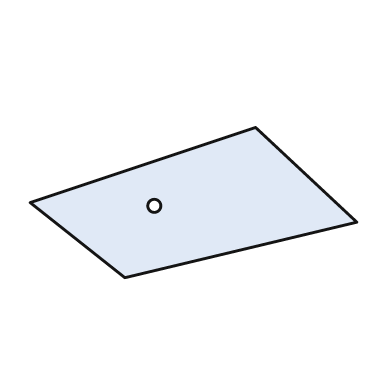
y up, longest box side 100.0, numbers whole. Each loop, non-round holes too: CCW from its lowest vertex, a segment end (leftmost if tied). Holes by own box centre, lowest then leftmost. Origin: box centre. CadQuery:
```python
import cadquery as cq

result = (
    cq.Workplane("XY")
    .moveTo(-21.0, -23.0)
    .lineTo(50.0, -6.0)
    .lineTo(19.0, 23.0)
    .lineTo(-50.0, 0.0)
    .close()
    .moveTo(-12.0, -1.0)
    .circle(2.0)
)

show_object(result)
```